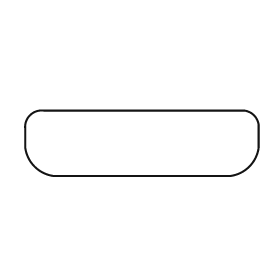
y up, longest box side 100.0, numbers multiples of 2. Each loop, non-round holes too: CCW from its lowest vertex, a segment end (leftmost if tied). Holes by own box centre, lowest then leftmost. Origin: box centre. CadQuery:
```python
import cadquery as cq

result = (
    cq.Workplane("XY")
    .moveTo(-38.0, -14.0)
    .lineTo(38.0, -14.0)
    .threePointArc((46.0, -10.0), (50.0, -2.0))
    .lineTo(50.0, 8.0)
    .threePointArc((48.0, 12.0), (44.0, 14.0))
    .lineTo(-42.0, 14.0)
    .threePointArc((-48.0, 12.0), (-50.0, 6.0))
    .lineTo(-50.0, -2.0)
    .threePointArc((-46.0, -10.0), (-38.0, -14.0))
    .close()
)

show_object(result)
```